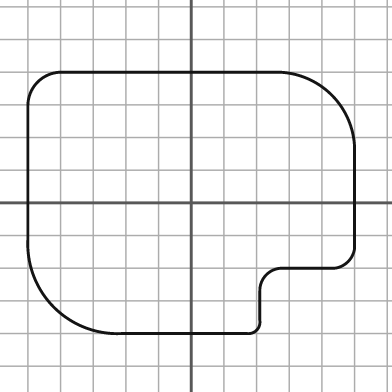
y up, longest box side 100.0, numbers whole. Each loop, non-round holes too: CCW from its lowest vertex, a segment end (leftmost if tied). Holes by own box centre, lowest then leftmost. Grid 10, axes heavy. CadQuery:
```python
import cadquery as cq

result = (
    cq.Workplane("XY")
    .moveTo(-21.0, -40.0)
    .lineTo(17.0, -40.0)
    .threePointArc((20.0, -39.0), (21.0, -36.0))
    .lineTo(21.0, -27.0)
    .threePointArc((23.0, -22.0), (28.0, -20.0))
    .lineTo(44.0, -20.0)
    .threePointArc((48.0, -18.0), (50.0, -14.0))
    .lineTo(50.0, 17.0)
    .threePointArc((43.0, 33.0), (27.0, 40.0))
    .lineTo(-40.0, 40.0)
    .threePointArc((-47.0, 37.0), (-50.0, 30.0))
    .lineTo(-50.0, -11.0)
    .threePointArc((-42.0, -32.0), (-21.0, -40.0))
    .close()
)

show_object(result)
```